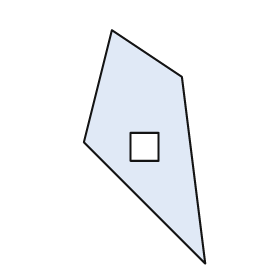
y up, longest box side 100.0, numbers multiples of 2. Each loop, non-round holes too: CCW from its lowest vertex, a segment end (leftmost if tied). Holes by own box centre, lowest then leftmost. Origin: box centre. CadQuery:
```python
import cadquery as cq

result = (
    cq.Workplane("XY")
    .moveTo(26.0, -50.0)
    .lineTo(16.0, 30.0)
    .lineTo(-14.0, 50.0)
    .lineTo(-26.0, 2.0)
    .close()
    .moveTo(-6.0, -6.0)
    .lineTo(6.0, -6.0)
    .lineTo(6.0, 6.0)
    .lineTo(-6.0, 6.0)
    .close()
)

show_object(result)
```